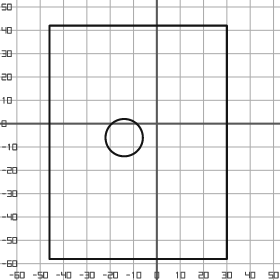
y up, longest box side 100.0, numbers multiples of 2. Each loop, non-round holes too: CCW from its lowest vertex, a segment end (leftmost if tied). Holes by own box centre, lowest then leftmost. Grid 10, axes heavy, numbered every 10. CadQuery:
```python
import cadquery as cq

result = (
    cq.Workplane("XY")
    .moveTo(-46.0, -58.0)
    .lineTo(30.0, -58.0)
    .lineTo(30.0, 42.0)
    .lineTo(-46.0, 42.0)
    .close()
    .moveTo(-14.0, -6.0)
    .circle(8.0)
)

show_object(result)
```